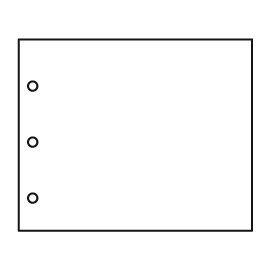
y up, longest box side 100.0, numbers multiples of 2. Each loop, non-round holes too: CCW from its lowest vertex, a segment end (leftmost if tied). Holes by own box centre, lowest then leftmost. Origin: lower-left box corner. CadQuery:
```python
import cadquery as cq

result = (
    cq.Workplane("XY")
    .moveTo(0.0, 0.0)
    .lineTo(100.0, 0.0)
    .lineTo(100.0, 82.0)
    .lineTo(0.0, 82.0)
    .close()
    .moveTo(6.0, 14.0)
    .circle(2.0)
    .moveTo(6.0, 38.0)
    .circle(2.0)
    .moveTo(6.0, 62.0)
    .circle(2.0)
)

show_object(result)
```